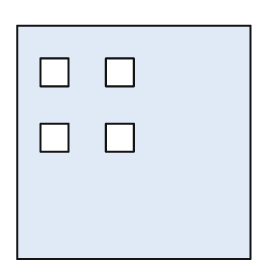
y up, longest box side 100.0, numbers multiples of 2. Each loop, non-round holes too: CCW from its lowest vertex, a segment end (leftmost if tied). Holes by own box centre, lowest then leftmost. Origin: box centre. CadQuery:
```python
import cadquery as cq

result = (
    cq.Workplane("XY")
    .moveTo(-50.0, -50.0)
    .lineTo(50.0, -50.0)
    .lineTo(50.0, 50.0)
    .lineTo(-50.0, 50.0)
    .close()
    .moveTo(-40.0, -4.0)
    .lineTo(-28.0, -4.0)
    .lineTo(-28.0, 8.0)
    .lineTo(-40.0, 8.0)
    .close()
    .moveTo(-12.0, -4.0)
    .lineTo(0.0, -4.0)
    .lineTo(0.0, 8.0)
    .lineTo(-12.0, 8.0)
    .close()
    .moveTo(-40.0, 24.0)
    .lineTo(-28.0, 24.0)
    .lineTo(-28.0, 36.0)
    .lineTo(-40.0, 36.0)
    .close()
    .moveTo(-12.0, 24.0)
    .lineTo(0.0, 24.0)
    .lineTo(0.0, 36.0)
    .lineTo(-12.0, 36.0)
    .close()
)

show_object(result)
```